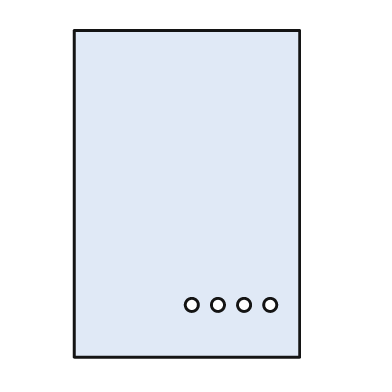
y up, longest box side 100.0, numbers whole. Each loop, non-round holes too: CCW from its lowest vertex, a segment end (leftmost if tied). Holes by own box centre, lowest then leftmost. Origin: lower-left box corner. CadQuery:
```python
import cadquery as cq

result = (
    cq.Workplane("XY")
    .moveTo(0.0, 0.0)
    .lineTo(69.0, 0.0)
    .lineTo(69.0, 100.0)
    .lineTo(0.0, 100.0)
    .close()
    .moveTo(36.0, 16.0)
    .circle(2.0)
    .moveTo(44.0, 16.0)
    .circle(2.0)
    .moveTo(52.0, 16.0)
    .circle(2.0)
    .moveTo(60.0, 16.0)
    .circle(2.0)
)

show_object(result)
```